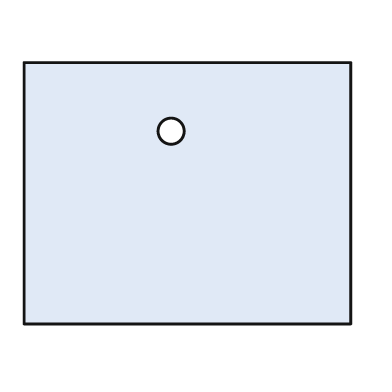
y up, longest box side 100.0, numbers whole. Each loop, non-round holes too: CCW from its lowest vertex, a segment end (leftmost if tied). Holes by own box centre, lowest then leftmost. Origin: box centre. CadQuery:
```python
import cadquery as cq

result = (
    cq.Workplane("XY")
    .moveTo(-50.0, -40.0)
    .lineTo(50.0, -40.0)
    .lineTo(50.0, 40.0)
    .lineTo(-50.0, 40.0)
    .close()
    .moveTo(-5.0, 19.0)
    .circle(4.0)
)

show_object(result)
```